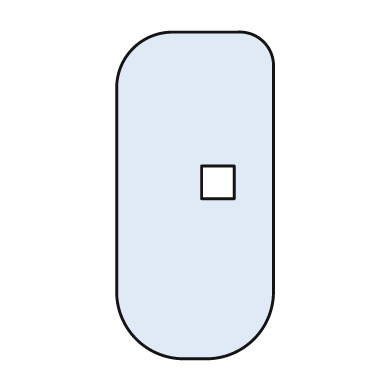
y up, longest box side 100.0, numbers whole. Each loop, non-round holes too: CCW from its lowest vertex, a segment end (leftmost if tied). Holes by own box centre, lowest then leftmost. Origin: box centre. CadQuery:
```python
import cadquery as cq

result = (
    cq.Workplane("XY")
    .moveTo(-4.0, -50.0)
    .lineTo(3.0, -50.0)
    .threePointArc((18.0, -44.0), (24.0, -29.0))
    .lineTo(24.0, 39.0)
    .threePointArc((21.0, 47.0), (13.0, 50.0))
    .lineTo(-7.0, 50.0)
    .threePointArc((-19.0, 45.0), (-24.0, 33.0))
    .lineTo(-24.0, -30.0)
    .threePointArc((-18.0, -44.0), (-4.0, -50.0))
    .close()
    .moveTo(2.0, -1.0)
    .lineTo(12.0, -1.0)
    .lineTo(12.0, 9.0)
    .lineTo(2.0, 9.0)
    .close()
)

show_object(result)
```